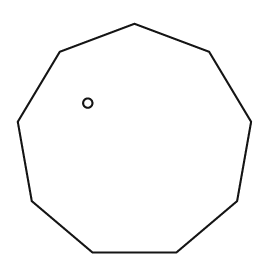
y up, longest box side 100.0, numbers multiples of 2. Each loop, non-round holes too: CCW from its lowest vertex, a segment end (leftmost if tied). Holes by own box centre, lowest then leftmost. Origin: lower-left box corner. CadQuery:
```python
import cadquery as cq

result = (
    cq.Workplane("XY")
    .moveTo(32.0, 0.0)
    .lineTo(68.0, 0.0)
    .lineTo(94.0, 22.0)
    .lineTo(100.0, 56.0)
    .lineTo(82.0, 86.0)
    .lineTo(50.0, 98.0)
    .lineTo(18.0, 86.0)
    .lineTo(0.0, 56.0)
    .lineTo(6.0, 22.0)
    .close()
    .moveTo(30.0, 64.0)
    .circle(2.0)
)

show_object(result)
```